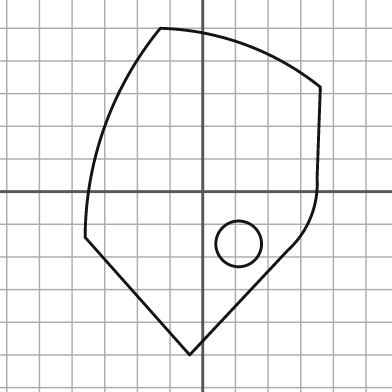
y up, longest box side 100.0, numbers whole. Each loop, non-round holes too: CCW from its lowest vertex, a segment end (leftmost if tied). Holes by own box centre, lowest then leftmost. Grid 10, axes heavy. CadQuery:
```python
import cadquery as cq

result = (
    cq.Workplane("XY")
    .moveTo(-4.0, -50.0)
    .lineTo(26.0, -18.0)
    .threePointArc((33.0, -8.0), (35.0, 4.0))
    .lineTo(36.0, 32.0)
    .threePointArc((13.0, 45.0), (-13.0, 50.0))
    .threePointArc((-30.0, 20.0), (-36.0, -14.0))
    .close()
    .moveTo(11.0, -16.0)
    .circle(7.0)
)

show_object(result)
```